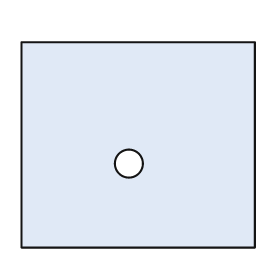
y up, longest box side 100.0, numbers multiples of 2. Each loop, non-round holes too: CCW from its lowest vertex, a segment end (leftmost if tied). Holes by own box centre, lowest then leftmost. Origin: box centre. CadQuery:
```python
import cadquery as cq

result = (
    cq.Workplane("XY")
    .moveTo(-50.0, -44.0)
    .lineTo(50.0, -44.0)
    .lineTo(50.0, 44.0)
    .lineTo(-50.0, 44.0)
    .close()
    .moveTo(-4.0, -8.0)
    .circle(6.0)
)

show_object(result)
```